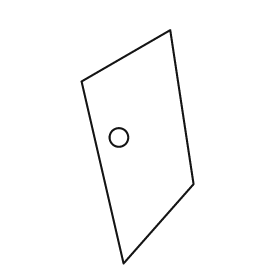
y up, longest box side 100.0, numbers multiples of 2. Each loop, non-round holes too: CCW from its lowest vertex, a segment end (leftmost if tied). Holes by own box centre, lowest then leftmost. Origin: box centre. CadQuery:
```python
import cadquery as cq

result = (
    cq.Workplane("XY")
    .moveTo(-6.0, -50.0)
    .lineTo(24.0, -16.0)
    .lineTo(14.0, 50.0)
    .lineTo(-24.0, 28.0)
    .close()
    .moveTo(-8.0, 4.0)
    .circle(4.0)
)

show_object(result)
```